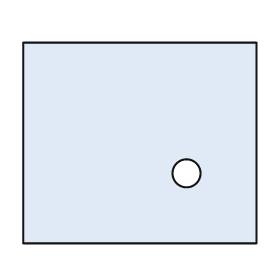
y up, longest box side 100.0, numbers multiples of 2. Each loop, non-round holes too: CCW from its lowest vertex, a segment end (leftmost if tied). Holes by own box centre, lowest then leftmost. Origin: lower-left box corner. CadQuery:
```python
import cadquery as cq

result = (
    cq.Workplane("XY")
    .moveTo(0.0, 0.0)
    .lineTo(100.0, 0.0)
    .lineTo(100.0, 86.0)
    .lineTo(0.0, 86.0)
    .close()
    .moveTo(70.0, 30.0)
    .circle(6.0)
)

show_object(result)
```